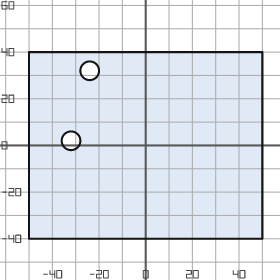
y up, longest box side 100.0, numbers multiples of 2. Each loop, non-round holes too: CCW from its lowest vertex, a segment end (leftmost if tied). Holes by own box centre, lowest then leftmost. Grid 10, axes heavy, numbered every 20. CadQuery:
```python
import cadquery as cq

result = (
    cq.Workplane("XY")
    .moveTo(-50.0, -40.0)
    .lineTo(50.0, -40.0)
    .lineTo(50.0, 40.0)
    .lineTo(-50.0, 40.0)
    .close()
    .moveTo(-32.0, 2.0)
    .circle(4.0)
    .moveTo(-24.0, 32.0)
    .circle(4.0)
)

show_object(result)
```